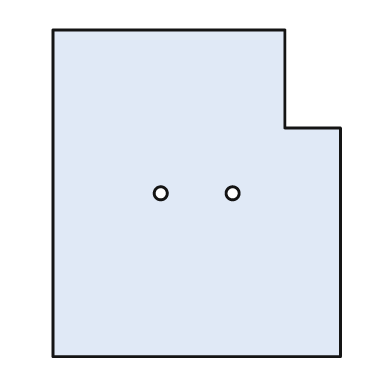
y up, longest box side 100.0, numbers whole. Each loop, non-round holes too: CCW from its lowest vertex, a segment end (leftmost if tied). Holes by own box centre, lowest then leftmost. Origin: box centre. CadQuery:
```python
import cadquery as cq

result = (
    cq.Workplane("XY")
    .moveTo(-44.0, -50.0)
    .lineTo(44.0, -50.0)
    .lineTo(44.0, 20.0)
    .lineTo(27.0, 20.0)
    .lineTo(27.0, 50.0)
    .lineTo(-44.0, 50.0)
    .close()
    .moveTo(-11.0, 0.0)
    .circle(2.0)
    .moveTo(11.0, 0.0)
    .circle(2.0)
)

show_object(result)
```